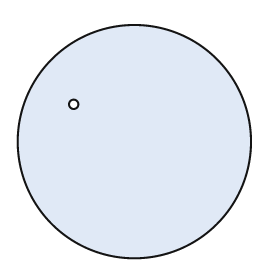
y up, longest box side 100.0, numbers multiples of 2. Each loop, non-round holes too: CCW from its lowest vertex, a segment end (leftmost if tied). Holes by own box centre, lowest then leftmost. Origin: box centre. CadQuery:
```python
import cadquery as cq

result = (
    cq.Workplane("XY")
    .moveTo(0.0, 0.0)
    .circle(50.0)
    .moveTo(-26.0, 16.0)
    .circle(2.0)
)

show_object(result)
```